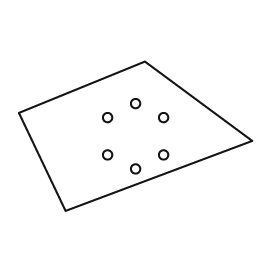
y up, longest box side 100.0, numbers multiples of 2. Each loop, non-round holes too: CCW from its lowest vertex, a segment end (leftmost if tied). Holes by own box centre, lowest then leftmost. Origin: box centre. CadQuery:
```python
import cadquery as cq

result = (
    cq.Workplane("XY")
    .moveTo(-30.0, -32.0)
    .lineTo(50.0, -2.0)
    .lineTo(4.0, 32.0)
    .lineTo(-50.0, 10.0)
    .close()
    .moveTo(0.0, -14.0)
    .circle(2.0)
    .moveTo(-12.0, -8.0)
    .circle(2.0)
    .moveTo(12.0, -8.0)
    .circle(2.0)
    .moveTo(-12.0, 8.0)
    .circle(2.0)
    .moveTo(12.0, 8.0)
    .circle(2.0)
    .moveTo(0.0, 14.0)
    .circle(2.0)
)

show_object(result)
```